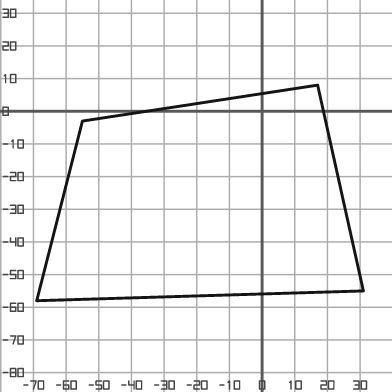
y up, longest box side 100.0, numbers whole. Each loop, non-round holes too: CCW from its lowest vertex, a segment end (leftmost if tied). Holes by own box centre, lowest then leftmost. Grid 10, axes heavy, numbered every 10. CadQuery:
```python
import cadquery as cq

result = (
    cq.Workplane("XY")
    .moveTo(-69.0, -58.0)
    .lineTo(31.0, -55.0)
    .lineTo(17.0, 8.0)
    .lineTo(-55.0, -3.0)
    .close()
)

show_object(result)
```